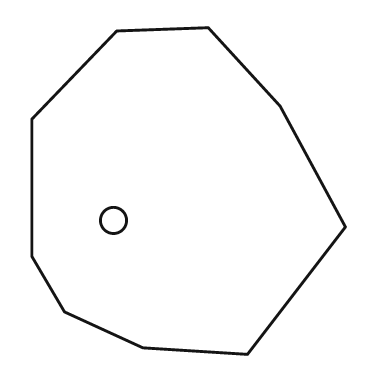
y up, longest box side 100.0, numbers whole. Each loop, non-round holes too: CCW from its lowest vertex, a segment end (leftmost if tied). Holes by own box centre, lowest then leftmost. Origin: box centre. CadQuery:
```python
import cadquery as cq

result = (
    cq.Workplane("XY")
    .moveTo(18.0, -50.0)
    .lineTo(48.0, -11.0)
    .lineTo(28.0, 26.0)
    .lineTo(6.0, 50.0)
    .lineTo(-22.0, 49.0)
    .lineTo(-48.0, 22.0)
    .lineTo(-48.0, -20.0)
    .lineTo(-38.0, -37.0)
    .lineTo(-14.0, -48.0)
    .close()
    .moveTo(-23.0, -9.0)
    .circle(4.0)
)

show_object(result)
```